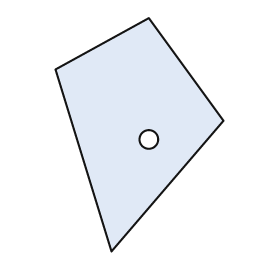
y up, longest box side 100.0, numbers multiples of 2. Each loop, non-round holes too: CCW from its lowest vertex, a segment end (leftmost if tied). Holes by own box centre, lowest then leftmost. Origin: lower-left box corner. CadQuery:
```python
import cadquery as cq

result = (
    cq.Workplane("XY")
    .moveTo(24.0, 0.0)
    .lineTo(72.0, 56.0)
    .lineTo(40.0, 100.0)
    .lineTo(0.0, 78.0)
    .close()
    .moveTo(40.0, 48.0)
    .circle(4.0)
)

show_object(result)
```